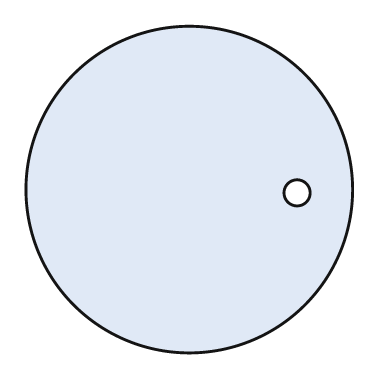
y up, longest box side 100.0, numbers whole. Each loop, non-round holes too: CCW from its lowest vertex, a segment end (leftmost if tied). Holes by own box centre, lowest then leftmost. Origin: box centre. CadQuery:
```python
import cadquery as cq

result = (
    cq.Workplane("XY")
    .moveTo(0.0, 0.0)
    .circle(50.0)
    .moveTo(33.0, -1.0)
    .circle(4.0)
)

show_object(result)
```